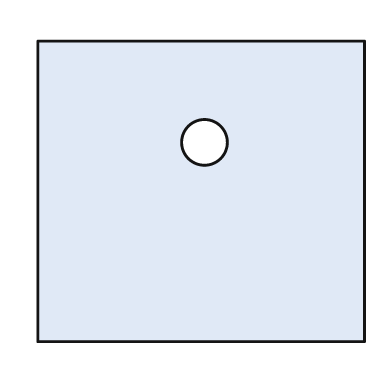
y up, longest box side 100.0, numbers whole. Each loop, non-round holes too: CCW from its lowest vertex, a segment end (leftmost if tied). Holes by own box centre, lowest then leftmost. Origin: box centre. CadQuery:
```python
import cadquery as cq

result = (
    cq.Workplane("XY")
    .moveTo(-50.0, -46.0)
    .lineTo(50.0, -46.0)
    .lineTo(50.0, 46.0)
    .lineTo(-50.0, 46.0)
    .close()
    .moveTo(1.0, 15.0)
    .circle(7.0)
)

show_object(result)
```